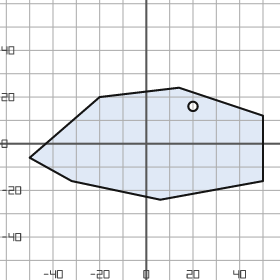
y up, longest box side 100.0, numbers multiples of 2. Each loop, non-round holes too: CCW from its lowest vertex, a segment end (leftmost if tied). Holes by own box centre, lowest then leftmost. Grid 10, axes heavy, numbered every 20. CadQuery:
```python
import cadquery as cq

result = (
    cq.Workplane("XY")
    .moveTo(6.0, -24.0)
    .lineTo(50.0, -16.0)
    .lineTo(50.0, 12.0)
    .lineTo(14.0, 24.0)
    .lineTo(-20.0, 20.0)
    .lineTo(-50.0, -6.0)
    .lineTo(-32.0, -16.0)
    .close()
    .moveTo(20.0, 16.0)
    .circle(2.0)
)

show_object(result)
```